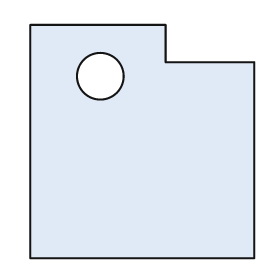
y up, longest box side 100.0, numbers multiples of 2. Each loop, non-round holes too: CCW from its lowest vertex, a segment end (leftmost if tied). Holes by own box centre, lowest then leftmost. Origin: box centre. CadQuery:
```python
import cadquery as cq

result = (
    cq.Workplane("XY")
    .moveTo(-48.0, -50.0)
    .lineTo(48.0, -50.0)
    .lineTo(48.0, 34.0)
    .lineTo(10.0, 34.0)
    .lineTo(10.0, 50.0)
    .lineTo(-48.0, 50.0)
    .close()
    .moveTo(-18.0, 28.0)
    .circle(10.0)
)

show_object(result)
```